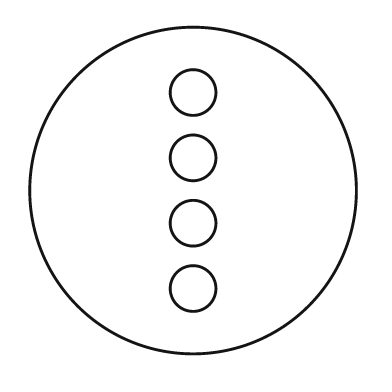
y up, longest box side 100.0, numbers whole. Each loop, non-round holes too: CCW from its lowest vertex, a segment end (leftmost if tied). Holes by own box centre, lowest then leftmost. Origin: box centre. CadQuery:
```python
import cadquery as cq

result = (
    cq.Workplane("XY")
    .moveTo(0.0, 0.0)
    .circle(50.0)
    .moveTo(0.0, -30.0)
    .circle(7.0)
    .moveTo(0.0, -10.0)
    .circle(7.0)
    .moveTo(0.0, 10.0)
    .circle(7.0)
    .moveTo(0.0, 30.0)
    .circle(7.0)
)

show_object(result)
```